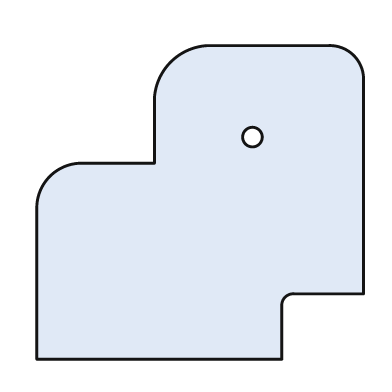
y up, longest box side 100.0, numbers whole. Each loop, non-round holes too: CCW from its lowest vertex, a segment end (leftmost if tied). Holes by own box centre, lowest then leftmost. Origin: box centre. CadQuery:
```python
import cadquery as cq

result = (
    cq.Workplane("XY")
    .moveTo(-50.0, -48.0)
    .lineTo(25.0, -48.0)
    .lineTo(25.0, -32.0)
    .threePointArc((26.0, -29.0), (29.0, -28.0))
    .lineTo(50.0, -28.0)
    .lineTo(50.0, 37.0)
    .threePointArc((47.0, 45.0), (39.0, 48.0))
    .lineTo(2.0, 48.0)
    .threePointArc((-9.0, 43.0), (-14.0, 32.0))
    .lineTo(-14.0, 12.0)
    .lineTo(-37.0, 12.0)
    .threePointArc((-46.0, 8.0), (-50.0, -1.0))
    .close()
    .moveTo(16.0, 20.0)
    .circle(3.0)
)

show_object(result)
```